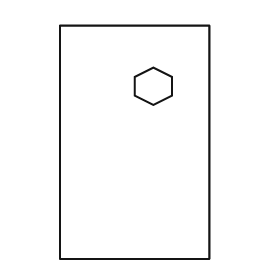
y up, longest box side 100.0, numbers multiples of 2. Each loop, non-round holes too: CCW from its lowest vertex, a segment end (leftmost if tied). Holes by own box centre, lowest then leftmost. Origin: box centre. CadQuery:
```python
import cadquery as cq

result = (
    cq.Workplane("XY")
    .moveTo(-32.0, -50.0)
    .lineTo(32.0, -50.0)
    .lineTo(32.0, 50.0)
    .lineTo(-32.0, 50.0)
    .close()
    .moveTo(8.0, 16.0)
    .lineTo(16.0, 20.0)
    .lineTo(16.0, 28.0)
    .lineTo(8.0, 32.0)
    .lineTo(0.0, 28.0)
    .lineTo(0.0, 20.0)
    .close()
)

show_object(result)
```